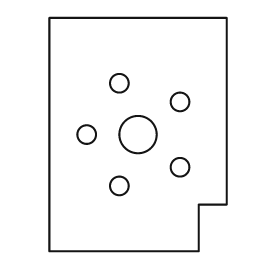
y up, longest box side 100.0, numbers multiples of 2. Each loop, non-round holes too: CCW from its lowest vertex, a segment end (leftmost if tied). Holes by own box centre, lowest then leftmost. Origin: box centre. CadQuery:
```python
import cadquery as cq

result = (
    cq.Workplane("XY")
    .moveTo(-38.0, -50.0)
    .lineTo(26.0, -50.0)
    .lineTo(26.0, -30.0)
    .lineTo(38.0, -30.0)
    .lineTo(38.0, 50.0)
    .lineTo(-38.0, 50.0)
    .close()
    .moveTo(-8.0, -22.0)
    .circle(4.0)
    .moveTo(18.0, -14.0)
    .circle(4.0)
    .moveTo(-22.0, 0.0)
    .circle(4.0)
    .moveTo(0.0, 0.0)
    .circle(8.0)
    .moveTo(18.0, 14.0)
    .circle(4.0)
    .moveTo(-8.0, 22.0)
    .circle(4.0)
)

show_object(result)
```